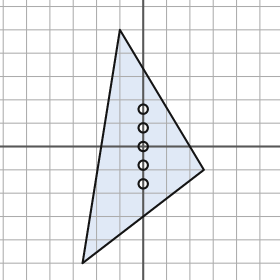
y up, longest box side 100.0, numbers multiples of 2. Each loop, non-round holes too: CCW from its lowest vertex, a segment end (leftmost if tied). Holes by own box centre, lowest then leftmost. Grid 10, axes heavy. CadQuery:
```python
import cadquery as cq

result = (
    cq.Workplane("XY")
    .moveTo(-26.0, -50.0)
    .lineTo(26.0, -10.0)
    .lineTo(-10.0, 50.0)
    .close()
    .moveTo(0.0, -16.0)
    .circle(2.0)
    .moveTo(0.0, -8.0)
    .circle(2.0)
    .moveTo(0.0, 0.0)
    .circle(2.0)
    .moveTo(0.0, 8.0)
    .circle(2.0)
    .moveTo(0.0, 16.0)
    .circle(2.0)
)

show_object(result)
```